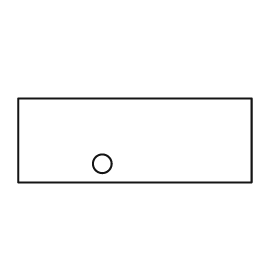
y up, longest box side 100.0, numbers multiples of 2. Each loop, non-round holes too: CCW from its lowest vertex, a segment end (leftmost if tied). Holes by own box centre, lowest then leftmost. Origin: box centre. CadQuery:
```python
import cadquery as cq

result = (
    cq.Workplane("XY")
    .moveTo(-50.0, -18.0)
    .lineTo(50.0, -18.0)
    .lineTo(50.0, 18.0)
    .lineTo(-50.0, 18.0)
    .close()
    .moveTo(-14.0, -10.0)
    .circle(4.0)
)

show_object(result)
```